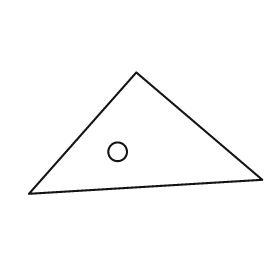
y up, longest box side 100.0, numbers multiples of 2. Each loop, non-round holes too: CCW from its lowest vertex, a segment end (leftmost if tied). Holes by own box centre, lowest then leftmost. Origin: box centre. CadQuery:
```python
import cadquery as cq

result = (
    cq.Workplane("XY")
    .moveTo(-50.0, -26.0)
    .lineTo(50.0, -20.0)
    .lineTo(-4.0, 26.0)
    .close()
    .moveTo(-12.0, -8.0)
    .circle(4.0)
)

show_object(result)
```